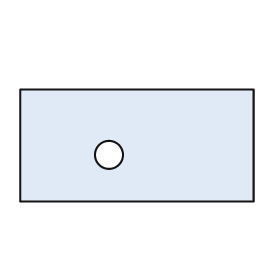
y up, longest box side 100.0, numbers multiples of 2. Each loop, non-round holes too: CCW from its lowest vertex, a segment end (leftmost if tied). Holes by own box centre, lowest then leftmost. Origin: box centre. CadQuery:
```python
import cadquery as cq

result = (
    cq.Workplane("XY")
    .moveTo(-50.0, -24.0)
    .lineTo(50.0, -24.0)
    .lineTo(50.0, 24.0)
    .lineTo(-50.0, 24.0)
    .close()
    .moveTo(-12.0, -4.0)
    .circle(6.0)
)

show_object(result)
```